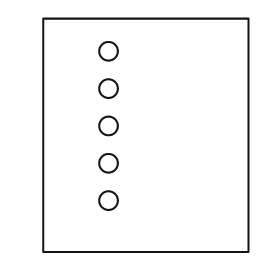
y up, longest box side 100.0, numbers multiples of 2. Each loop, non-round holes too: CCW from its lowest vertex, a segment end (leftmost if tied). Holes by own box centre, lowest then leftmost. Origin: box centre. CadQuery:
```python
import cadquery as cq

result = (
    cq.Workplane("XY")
    .moveTo(-44.0, -50.0)
    .lineTo(44.0, -50.0)
    .lineTo(44.0, 50.0)
    .lineTo(-44.0, 50.0)
    .close()
    .moveTo(-16.0, -28.0)
    .circle(4.0)
    .moveTo(-16.0, -12.0)
    .circle(4.0)
    .moveTo(-16.0, 4.0)
    .circle(4.0)
    .moveTo(-16.0, 20.0)
    .circle(4.0)
    .moveTo(-16.0, 36.0)
    .circle(4.0)
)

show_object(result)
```